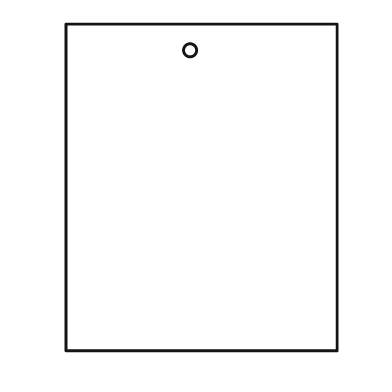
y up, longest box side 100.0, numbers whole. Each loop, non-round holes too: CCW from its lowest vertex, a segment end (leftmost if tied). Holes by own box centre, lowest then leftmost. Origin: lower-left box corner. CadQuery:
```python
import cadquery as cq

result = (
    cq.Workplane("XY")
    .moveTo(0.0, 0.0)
    .lineTo(83.0, 0.0)
    .lineTo(83.0, 100.0)
    .lineTo(0.0, 100.0)
    .close()
    .moveTo(38.0, 92.0)
    .circle(2.0)
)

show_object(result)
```